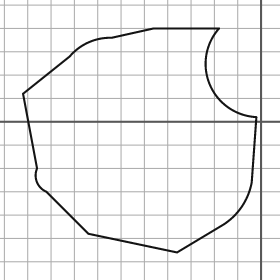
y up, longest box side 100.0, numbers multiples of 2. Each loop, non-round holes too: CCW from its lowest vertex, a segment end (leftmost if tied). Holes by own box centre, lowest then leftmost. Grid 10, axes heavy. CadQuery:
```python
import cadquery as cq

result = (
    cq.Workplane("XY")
    .moveTo(-36.0, -56.0)
    .lineTo(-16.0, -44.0)
    .threePointArc((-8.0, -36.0), (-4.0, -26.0))
    .lineTo(-2.0, 2.0)
    .threePointArc((-22.0, 16.0), (-18.0, 40.0))
    .lineTo(-46.0, 40.0)
    .lineTo(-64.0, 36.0)
    .threePointArc((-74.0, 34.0), (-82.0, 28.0))
    .lineTo(-102.0, 12.0)
    .lineTo(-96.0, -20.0)
    .threePointArc((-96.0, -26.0), (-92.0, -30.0))
    .lineTo(-74.0, -48.0)
    .close()
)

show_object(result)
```